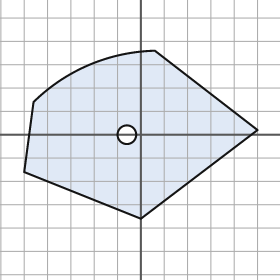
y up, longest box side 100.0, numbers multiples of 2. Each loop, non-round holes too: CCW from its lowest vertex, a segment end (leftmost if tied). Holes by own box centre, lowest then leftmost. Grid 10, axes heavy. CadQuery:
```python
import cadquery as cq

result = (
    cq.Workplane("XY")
    .moveTo(0.0, -36.0)
    .lineTo(50.0, 2.0)
    .lineTo(6.0, 36.0)
    .threePointArc((-22.0, 30.0), (-46.0, 14.0))
    .lineTo(-50.0, -16.0)
    .close()
    .moveTo(-6.0, 0.0)
    .circle(4.0)
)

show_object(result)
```